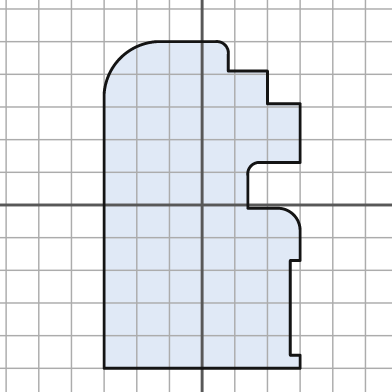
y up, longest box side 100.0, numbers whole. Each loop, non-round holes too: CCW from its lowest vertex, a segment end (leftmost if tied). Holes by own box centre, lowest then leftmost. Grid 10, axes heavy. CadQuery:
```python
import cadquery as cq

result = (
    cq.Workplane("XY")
    .moveTo(-30.0, -50.0)
    .lineTo(30.0, -50.0)
    .lineTo(30.0, -46.0)
    .lineTo(27.0, -46.0)
    .lineTo(27.0, -17.0)
    .lineTo(30.0, -17.0)
    .lineTo(30.0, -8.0)
    .threePointArc((28.0, -3.0), (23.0, -1.0))
    .lineTo(14.0, -1.0)
    .lineTo(14.0, 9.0)
    .threePointArc((15.0, 12.0), (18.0, 13.0))
    .lineTo(30.0, 13.0)
    .lineTo(30.0, 31.0)
    .lineTo(20.0, 31.0)
    .lineTo(20.0, 41.0)
    .lineTo(8.0, 41.0)
    .lineTo(8.0, 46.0)
    .threePointArc((7.0, 49.0), (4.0, 50.0))
    .lineTo(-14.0, 50.0)
    .threePointArc((-25.0, 45.0), (-30.0, 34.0))
    .close()
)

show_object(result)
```